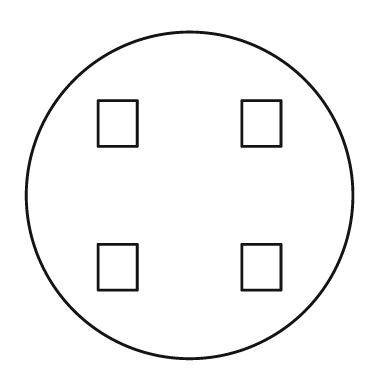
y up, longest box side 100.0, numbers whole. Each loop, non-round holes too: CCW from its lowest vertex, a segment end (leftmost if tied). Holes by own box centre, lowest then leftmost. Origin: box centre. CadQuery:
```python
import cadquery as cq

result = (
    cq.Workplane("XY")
    .moveTo(0.0, 0.0)
    .circle(50.0)
    .moveTo(-28.0, -29.0)
    .lineTo(-16.0, -29.0)
    .lineTo(-16.0, -15.0)
    .lineTo(-28.0, -15.0)
    .close()
    .moveTo(16.0, -29.0)
    .lineTo(28.0, -29.0)
    .lineTo(28.0, -15.0)
    .lineTo(16.0, -15.0)
    .close()
    .moveTo(-28.0, 15.0)
    .lineTo(-16.0, 15.0)
    .lineTo(-16.0, 29.0)
    .lineTo(-28.0, 29.0)
    .close()
    .moveTo(16.0, 15.0)
    .lineTo(28.0, 15.0)
    .lineTo(28.0, 29.0)
    .lineTo(16.0, 29.0)
    .close()
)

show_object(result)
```